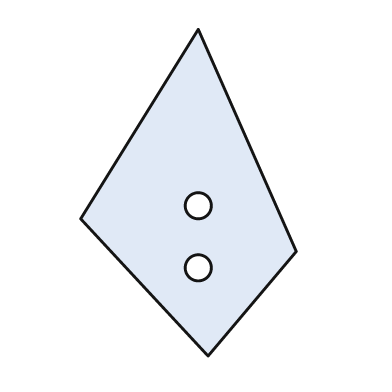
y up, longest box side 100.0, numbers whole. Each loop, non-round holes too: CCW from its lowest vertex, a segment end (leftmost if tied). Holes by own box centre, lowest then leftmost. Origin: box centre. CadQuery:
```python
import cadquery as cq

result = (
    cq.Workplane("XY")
    .moveTo(6.0, -50.0)
    .lineTo(33.0, -18.0)
    .lineTo(3.0, 50.0)
    .lineTo(-33.0, -8.0)
    .close()
    .moveTo(3.0, -23.0)
    .circle(4.0)
    .moveTo(3.0, -4.0)
    .circle(4.0)
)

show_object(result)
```